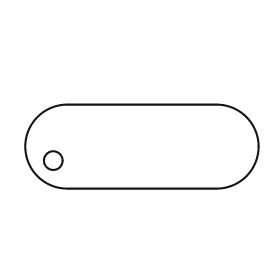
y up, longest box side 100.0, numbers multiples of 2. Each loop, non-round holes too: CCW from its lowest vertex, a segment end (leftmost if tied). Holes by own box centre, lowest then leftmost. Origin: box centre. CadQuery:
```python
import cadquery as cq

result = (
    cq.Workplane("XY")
    .moveTo(-32.0, -18.0)
    .lineTo(32.0, -18.0)
    .threePointArc((50.0, 0.0), (32.0, 18.0))
    .lineTo(-32.0, 18.0)
    .threePointArc((-50.0, 0.0), (-32.0, -18.0))
    .close()
    .moveTo(-38.0, -6.0)
    .circle(4.0)
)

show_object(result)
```